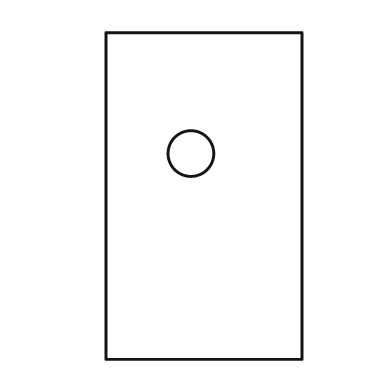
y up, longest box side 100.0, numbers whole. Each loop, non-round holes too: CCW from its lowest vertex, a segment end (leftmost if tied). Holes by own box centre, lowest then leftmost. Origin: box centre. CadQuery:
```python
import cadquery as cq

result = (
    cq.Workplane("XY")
    .moveTo(-30.0, -50.0)
    .lineTo(30.0, -50.0)
    .lineTo(30.0, 50.0)
    .lineTo(-30.0, 50.0)
    .close()
    .moveTo(-4.0, 13.0)
    .circle(7.0)
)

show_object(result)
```